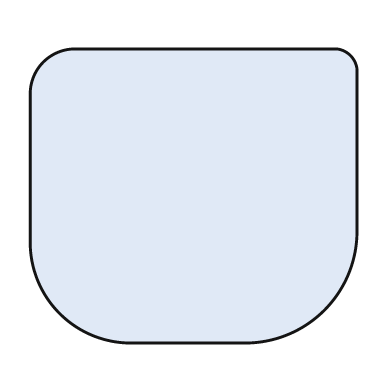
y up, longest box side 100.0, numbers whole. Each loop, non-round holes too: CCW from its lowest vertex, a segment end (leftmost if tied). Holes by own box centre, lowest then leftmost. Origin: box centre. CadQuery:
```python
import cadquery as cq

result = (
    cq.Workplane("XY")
    .moveTo(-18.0, -45.0)
    .lineTo(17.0, -45.0)
    .threePointArc((40.0, -35.0), (50.0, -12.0))
    .lineTo(50.0, 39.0)
    .threePointArc((48.0, 43.0), (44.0, 45.0))
    .lineTo(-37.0, 45.0)
    .threePointArc((-46.0, 41.0), (-50.0, 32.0))
    .lineTo(-50.0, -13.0)
    .threePointArc((-41.0, -36.0), (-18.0, -45.0))
    .close()
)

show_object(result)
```